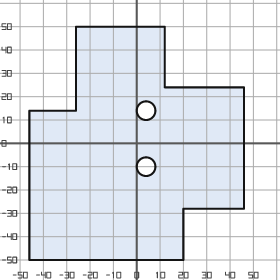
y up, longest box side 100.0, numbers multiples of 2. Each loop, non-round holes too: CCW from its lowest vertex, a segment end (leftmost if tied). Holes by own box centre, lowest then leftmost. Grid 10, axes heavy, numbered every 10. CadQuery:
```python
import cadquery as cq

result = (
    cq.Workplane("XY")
    .moveTo(-46.0, -50.0)
    .lineTo(20.0, -50.0)
    .lineTo(20.0, -28.0)
    .lineTo(46.0, -28.0)
    .lineTo(46.0, 24.0)
    .lineTo(12.0, 24.0)
    .lineTo(12.0, 50.0)
    .lineTo(-26.0, 50.0)
    .lineTo(-26.0, 14.0)
    .lineTo(-46.0, 14.0)
    .close()
    .moveTo(4.0, -10.0)
    .circle(4.0)
    .moveTo(4.0, 14.0)
    .circle(4.0)
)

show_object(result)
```